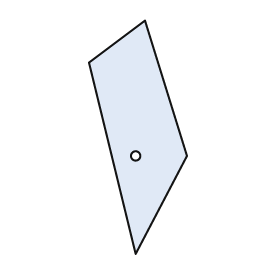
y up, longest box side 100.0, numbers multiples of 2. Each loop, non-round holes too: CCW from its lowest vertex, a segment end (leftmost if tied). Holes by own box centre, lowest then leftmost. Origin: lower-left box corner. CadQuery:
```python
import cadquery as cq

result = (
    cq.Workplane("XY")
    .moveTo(20.0, 0.0)
    .lineTo(42.0, 42.0)
    .lineTo(24.0, 100.0)
    .lineTo(0.0, 82.0)
    .close()
    .moveTo(20.0, 42.0)
    .circle(2.0)
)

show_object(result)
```